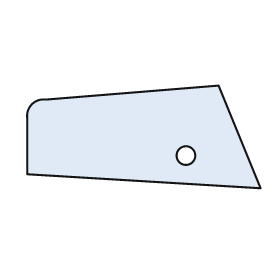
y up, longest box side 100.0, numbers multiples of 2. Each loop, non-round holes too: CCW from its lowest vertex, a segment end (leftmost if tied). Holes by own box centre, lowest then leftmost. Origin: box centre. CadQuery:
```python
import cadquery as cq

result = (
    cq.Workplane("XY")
    .moveTo(50.0, -22.0)
    .lineTo(32.0, 22.0)
    .lineTo(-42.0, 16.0)
    .threePointArc((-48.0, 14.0), (-50.0, 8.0))
    .lineTo(-50.0, -16.0)
    .close()
    .moveTo(18.0, -8.0)
    .circle(4.0)
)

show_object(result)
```